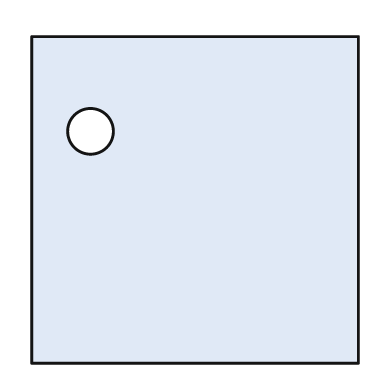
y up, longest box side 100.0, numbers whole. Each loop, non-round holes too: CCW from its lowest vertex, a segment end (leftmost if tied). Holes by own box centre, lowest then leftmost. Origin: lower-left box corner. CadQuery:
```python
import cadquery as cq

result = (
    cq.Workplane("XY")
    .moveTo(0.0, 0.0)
    .lineTo(100.0, 0.0)
    .lineTo(100.0, 100.0)
    .lineTo(0.0, 100.0)
    .close()
    .moveTo(18.0, 71.0)
    .circle(7.0)
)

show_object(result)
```